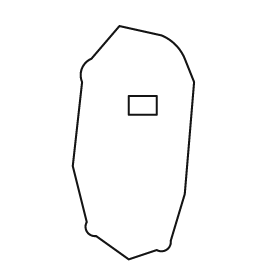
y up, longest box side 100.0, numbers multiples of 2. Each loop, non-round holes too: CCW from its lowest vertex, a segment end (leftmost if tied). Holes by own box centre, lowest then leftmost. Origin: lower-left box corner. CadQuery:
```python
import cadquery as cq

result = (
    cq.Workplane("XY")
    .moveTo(24.0, 0.0)
    .lineTo(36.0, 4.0)
    .threePointArc((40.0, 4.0), (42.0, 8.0))
    .lineTo(48.0, 28.0)
    .lineTo(52.0, 76.0)
    .lineTo(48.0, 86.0)
    .threePointArc((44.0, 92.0), (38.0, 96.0))
    .lineTo(20.0, 100.0)
    .lineTo(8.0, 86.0)
    .threePointArc((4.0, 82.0), (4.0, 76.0))
    .lineTo(0.0, 40.0)
    .lineTo(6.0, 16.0)
    .threePointArc((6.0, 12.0), (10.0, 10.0))
    .close()
    .moveTo(24.0, 62.0)
    .lineTo(36.0, 62.0)
    .lineTo(36.0, 70.0)
    .lineTo(24.0, 70.0)
    .close()
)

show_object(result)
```